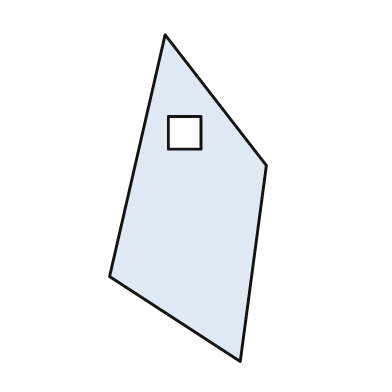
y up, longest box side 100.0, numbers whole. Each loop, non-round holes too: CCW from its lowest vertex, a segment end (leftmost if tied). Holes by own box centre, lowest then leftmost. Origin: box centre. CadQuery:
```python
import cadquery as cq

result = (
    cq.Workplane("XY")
    .moveTo(16.0, -50.0)
    .lineTo(24.0, 10.0)
    .lineTo(-7.0, 50.0)
    .lineTo(-24.0, -24.0)
    .close()
    .moveTo(-6.0, 15.0)
    .lineTo(4.0, 15.0)
    .lineTo(4.0, 25.0)
    .lineTo(-6.0, 25.0)
    .close()
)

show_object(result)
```